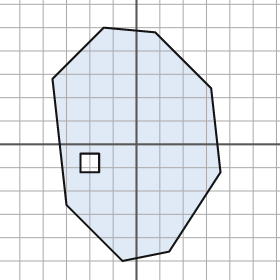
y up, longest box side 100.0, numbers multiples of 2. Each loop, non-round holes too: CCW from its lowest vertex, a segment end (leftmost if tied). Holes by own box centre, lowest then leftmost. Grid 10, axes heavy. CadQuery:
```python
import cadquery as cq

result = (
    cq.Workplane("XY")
    .moveTo(-6.0, -50.0)
    .lineTo(14.0, -46.0)
    .lineTo(36.0, -12.0)
    .lineTo(32.0, 24.0)
    .lineTo(8.0, 48.0)
    .lineTo(-14.0, 50.0)
    .lineTo(-36.0, 28.0)
    .lineTo(-30.0, -26.0)
    .close()
    .moveTo(-24.0, -12.0)
    .lineTo(-16.0, -12.0)
    .lineTo(-16.0, -4.0)
    .lineTo(-24.0, -4.0)
    .close()
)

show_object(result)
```